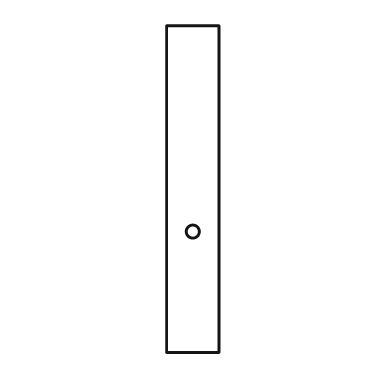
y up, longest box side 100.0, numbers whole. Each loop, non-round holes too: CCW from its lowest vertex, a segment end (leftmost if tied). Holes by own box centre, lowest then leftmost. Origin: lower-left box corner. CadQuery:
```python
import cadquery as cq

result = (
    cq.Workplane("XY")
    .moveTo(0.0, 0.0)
    .lineTo(16.0, 0.0)
    .lineTo(16.0, 100.0)
    .lineTo(0.0, 100.0)
    .close()
    .moveTo(8.0, 37.0)
    .circle(2.0)
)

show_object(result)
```